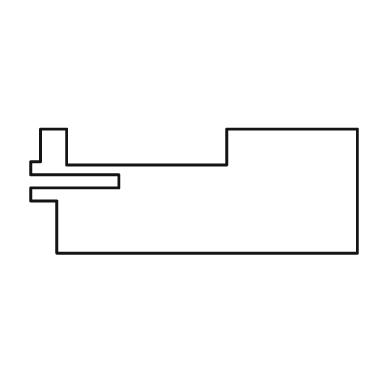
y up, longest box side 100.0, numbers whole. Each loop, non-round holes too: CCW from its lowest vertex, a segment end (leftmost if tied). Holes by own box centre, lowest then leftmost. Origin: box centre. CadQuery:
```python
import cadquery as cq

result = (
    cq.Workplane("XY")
    .moveTo(-42.0, -19.0)
    .lineTo(50.0, -19.0)
    .lineTo(50.0, 19.0)
    .lineTo(10.0, 19.0)
    .lineTo(10.0, 8.0)
    .lineTo(-39.0, 8.0)
    .lineTo(-39.0, 19.0)
    .lineTo(-47.0, 19.0)
    .lineTo(-47.0, 9.0)
    .lineTo(-50.0, 9.0)
    .lineTo(-50.0, 5.0)
    .lineTo(-23.0, 5.0)
    .lineTo(-23.0, 1.0)
    .lineTo(-50.0, 1.0)
    .lineTo(-50.0, -3.0)
    .lineTo(-42.0, -3.0)
    .close()
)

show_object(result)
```